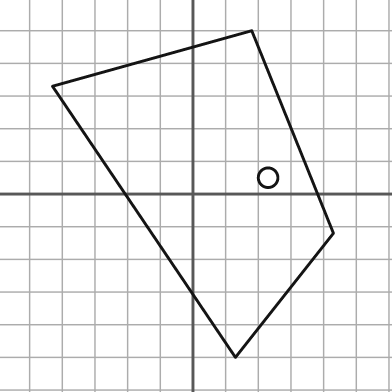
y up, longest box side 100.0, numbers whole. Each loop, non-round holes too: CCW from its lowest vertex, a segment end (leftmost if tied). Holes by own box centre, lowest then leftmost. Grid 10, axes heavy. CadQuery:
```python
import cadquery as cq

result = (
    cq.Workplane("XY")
    .moveTo(13.0, -50.0)
    .lineTo(43.0, -12.0)
    .lineTo(18.0, 50.0)
    .lineTo(-43.0, 33.0)
    .close()
    .moveTo(23.0, 5.0)
    .circle(3.0)
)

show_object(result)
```